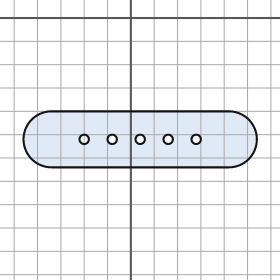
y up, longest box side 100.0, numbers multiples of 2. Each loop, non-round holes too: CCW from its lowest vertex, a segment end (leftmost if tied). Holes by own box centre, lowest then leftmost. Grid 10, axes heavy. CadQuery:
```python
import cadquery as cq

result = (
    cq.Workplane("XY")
    .moveTo(-34.0, -64.0)
    .lineTo(42.0, -64.0)
    .threePointArc((54.0, -52.0), (42.0, -40.0))
    .lineTo(-34.0, -40.0)
    .threePointArc((-46.0, -52.0), (-34.0, -64.0))
    .close()
    .moveTo(-20.0, -52.0)
    .circle(2.0)
    .moveTo(-8.0, -52.0)
    .circle(2.0)
    .moveTo(4.0, -52.0)
    .circle(2.0)
    .moveTo(16.0, -52.0)
    .circle(2.0)
    .moveTo(28.0, -52.0)
    .circle(2.0)
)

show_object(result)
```